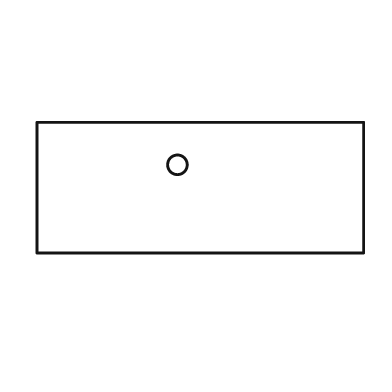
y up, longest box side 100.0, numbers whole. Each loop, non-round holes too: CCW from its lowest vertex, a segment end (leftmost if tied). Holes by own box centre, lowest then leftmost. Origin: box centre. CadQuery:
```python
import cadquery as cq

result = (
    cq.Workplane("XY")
    .moveTo(-50.0, -20.0)
    .lineTo(50.0, -20.0)
    .lineTo(50.0, 20.0)
    .lineTo(-50.0, 20.0)
    .close()
    .moveTo(-7.0, 7.0)
    .circle(3.0)
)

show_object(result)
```